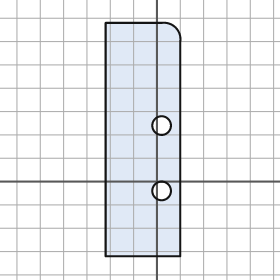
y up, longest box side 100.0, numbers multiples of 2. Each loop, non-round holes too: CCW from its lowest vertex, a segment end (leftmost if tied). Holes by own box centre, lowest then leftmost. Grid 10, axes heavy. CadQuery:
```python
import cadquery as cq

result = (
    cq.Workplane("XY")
    .moveTo(-22.0, -32.0)
    .lineTo(10.0, -32.0)
    .lineTo(10.0, 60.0)
    .threePointArc((8.0, 66.0), (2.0, 68.0))
    .lineTo(-22.0, 68.0)
    .close()
    .moveTo(2.0, -4.0)
    .circle(4.0)
    .moveTo(2.0, 24.0)
    .circle(4.0)
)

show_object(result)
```